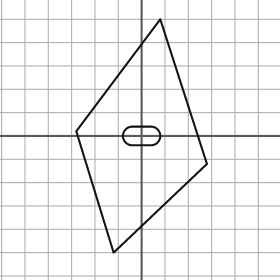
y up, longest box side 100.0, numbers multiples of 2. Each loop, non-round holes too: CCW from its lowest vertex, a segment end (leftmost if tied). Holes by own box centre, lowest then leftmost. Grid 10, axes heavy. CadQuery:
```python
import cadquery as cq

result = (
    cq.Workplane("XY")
    .moveTo(-12.0, -50.0)
    .lineTo(28.0, -12.0)
    .lineTo(8.0, 50.0)
    .lineTo(-28.0, 2.0)
    .close()
    .moveTo(-4.0, -4.0)
    .lineTo(4.0, -4.0)
    .threePointArc((8.0, 0.0), (4.0, 4.0))
    .lineTo(-4.0, 4.0)
    .threePointArc((-8.0, 0.0), (-4.0, -4.0))
    .close()
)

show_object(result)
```